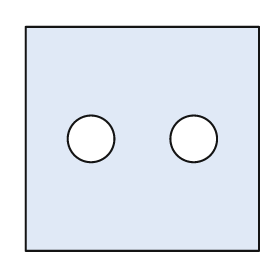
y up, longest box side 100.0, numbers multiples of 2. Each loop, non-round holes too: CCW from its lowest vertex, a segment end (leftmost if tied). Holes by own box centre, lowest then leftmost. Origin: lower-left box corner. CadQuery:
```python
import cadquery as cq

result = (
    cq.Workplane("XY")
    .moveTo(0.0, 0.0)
    .lineTo(100.0, 0.0)
    .lineTo(100.0, 96.0)
    .lineTo(0.0, 96.0)
    .close()
    .moveTo(28.0, 48.0)
    .circle(10.0)
    .moveTo(72.0, 48.0)
    .circle(10.0)
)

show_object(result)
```